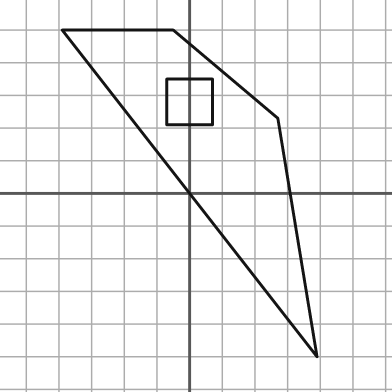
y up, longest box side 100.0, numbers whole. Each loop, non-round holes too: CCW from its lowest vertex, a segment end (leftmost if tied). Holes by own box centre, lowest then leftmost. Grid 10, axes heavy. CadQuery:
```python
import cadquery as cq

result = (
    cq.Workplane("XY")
    .moveTo(39.0, -50.0)
    .lineTo(27.0, 23.0)
    .lineTo(-5.0, 50.0)
    .lineTo(-39.0, 50.0)
    .close()
    .moveTo(-7.0, 21.0)
    .lineTo(7.0, 21.0)
    .lineTo(7.0, 35.0)
    .lineTo(-7.0, 35.0)
    .close()
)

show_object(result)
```